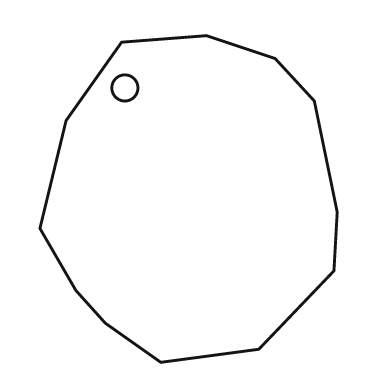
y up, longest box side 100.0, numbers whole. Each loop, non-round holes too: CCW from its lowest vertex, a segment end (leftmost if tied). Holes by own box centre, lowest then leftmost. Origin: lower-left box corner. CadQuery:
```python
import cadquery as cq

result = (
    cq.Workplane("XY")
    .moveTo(37.0, 0.0)
    .lineTo(67.0, 4.0)
    .lineTo(90.0, 28.0)
    .lineTo(91.0, 46.0)
    .lineTo(84.0, 80.0)
    .lineTo(72.0, 93.0)
    .lineTo(51.0, 100.0)
    .lineTo(25.0, 98.0)
    .lineTo(8.0, 74.0)
    .lineTo(0.0, 41.0)
    .lineTo(11.0, 22.0)
    .lineTo(20.0, 12.0)
    .close()
    .moveTo(26.0, 84.0)
    .circle(4.0)
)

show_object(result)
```